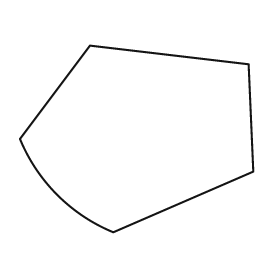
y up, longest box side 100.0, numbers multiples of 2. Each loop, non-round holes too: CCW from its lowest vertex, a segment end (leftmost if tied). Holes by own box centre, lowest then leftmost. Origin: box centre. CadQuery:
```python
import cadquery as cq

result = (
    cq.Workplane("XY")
    .moveTo(-10.0, -40.0)
    .lineTo(50.0, -14.0)
    .lineTo(48.0, 32.0)
    .lineTo(-20.0, 40.0)
    .lineTo(-50.0, 0.0)
    .threePointArc((-34.0, -24.0), (-10.0, -40.0))
    .close()
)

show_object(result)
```